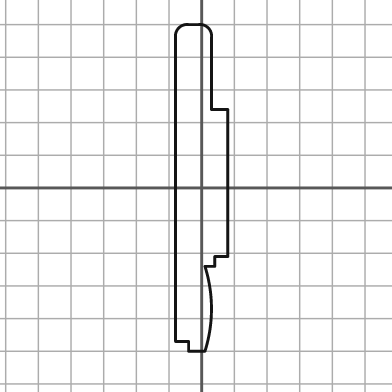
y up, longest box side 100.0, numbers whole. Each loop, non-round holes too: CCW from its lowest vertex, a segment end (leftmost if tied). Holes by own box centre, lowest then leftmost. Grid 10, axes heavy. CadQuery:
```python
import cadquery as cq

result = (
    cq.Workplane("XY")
    .moveTo(-4.0, -50.0)
    .lineTo(1.0, -50.0)
    .threePointArc((3.0, -37.0), (1.0, -24.0))
    .lineTo(4.0, -24.0)
    .lineTo(4.0, -21.0)
    .lineTo(8.0, -21.0)
    .lineTo(8.0, 24.0)
    .lineTo(3.0, 24.0)
    .lineTo(3.0, 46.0)
    .threePointArc((2.0, 49.0), (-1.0, 50.0))
    .lineTo(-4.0, 50.0)
    .threePointArc((-7.0, 49.0), (-8.0, 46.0))
    .lineTo(-8.0, -47.0)
    .lineTo(-4.0, -47.0)
    .close()
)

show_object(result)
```